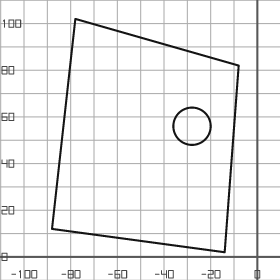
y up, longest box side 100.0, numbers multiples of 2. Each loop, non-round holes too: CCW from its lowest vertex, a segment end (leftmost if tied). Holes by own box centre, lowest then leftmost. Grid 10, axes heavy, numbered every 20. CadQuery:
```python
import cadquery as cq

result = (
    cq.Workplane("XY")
    .moveTo(-14.0, 2.0)
    .lineTo(-8.0, 82.0)
    .lineTo(-78.0, 102.0)
    .lineTo(-88.0, 12.0)
    .close()
    .moveTo(-28.0, 56.0)
    .circle(8.0)
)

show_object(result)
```